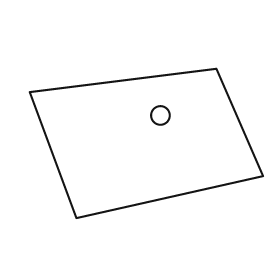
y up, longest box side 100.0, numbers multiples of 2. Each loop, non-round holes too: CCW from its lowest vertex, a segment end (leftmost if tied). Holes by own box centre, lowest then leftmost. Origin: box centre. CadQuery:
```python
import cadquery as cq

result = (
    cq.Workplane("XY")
    .moveTo(-30.0, -32.0)
    .lineTo(50.0, -14.0)
    .lineTo(30.0, 32.0)
    .lineTo(-50.0, 22.0)
    .close()
    .moveTo(6.0, 12.0)
    .circle(4.0)
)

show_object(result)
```